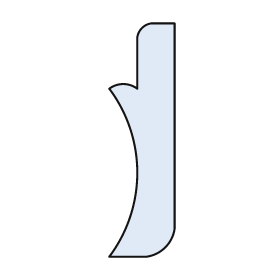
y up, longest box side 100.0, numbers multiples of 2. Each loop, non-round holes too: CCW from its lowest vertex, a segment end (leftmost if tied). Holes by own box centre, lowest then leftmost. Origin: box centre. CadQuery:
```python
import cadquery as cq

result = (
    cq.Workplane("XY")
    .moveTo(-14.0, -50.0)
    .lineTo(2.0, -50.0)
    .threePointArc((10.0, -46.0), (14.0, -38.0))
    .lineTo(14.0, 50.0)
    .lineTo(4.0, 50.0)
    .threePointArc((0.0, 48.0), (-2.0, 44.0))
    .lineTo(-2.0, 22.0)
    .threePointArc((-8.0, 24.0), (-14.0, 22.0))
    .threePointArc((-2.0, -14.0), (-14.0, -50.0))
    .close()
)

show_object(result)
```